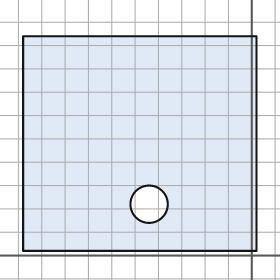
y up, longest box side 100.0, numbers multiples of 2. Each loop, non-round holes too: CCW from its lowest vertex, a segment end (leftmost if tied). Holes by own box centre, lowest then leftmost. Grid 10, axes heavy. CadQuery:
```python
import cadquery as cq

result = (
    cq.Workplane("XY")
    .moveTo(-98.0, 2.0)
    .lineTo(2.0, 2.0)
    .lineTo(2.0, 94.0)
    .lineTo(-98.0, 94.0)
    .close()
    .moveTo(-44.0, 22.0)
    .circle(8.0)
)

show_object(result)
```